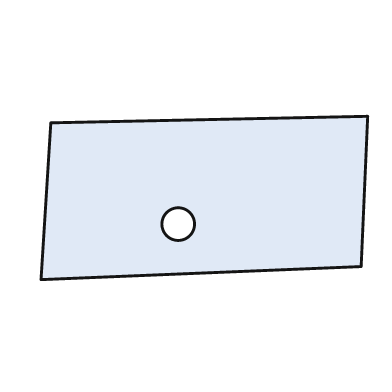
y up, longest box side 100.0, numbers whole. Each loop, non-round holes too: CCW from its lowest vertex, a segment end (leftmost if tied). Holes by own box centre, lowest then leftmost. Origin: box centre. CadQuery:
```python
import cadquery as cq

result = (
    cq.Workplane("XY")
    .moveTo(-50.0, -25.0)
    .lineTo(48.0, -21.0)
    .lineTo(50.0, 25.0)
    .lineTo(-47.0, 23.0)
    .close()
    .moveTo(-8.0, -8.0)
    .circle(5.0)
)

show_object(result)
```